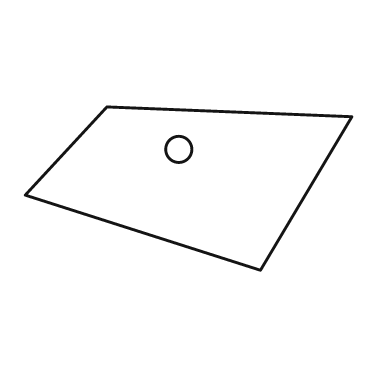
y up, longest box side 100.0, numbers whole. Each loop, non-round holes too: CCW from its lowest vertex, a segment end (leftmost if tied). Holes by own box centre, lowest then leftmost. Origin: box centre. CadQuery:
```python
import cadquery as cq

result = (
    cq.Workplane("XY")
    .moveTo(22.0, -25.0)
    .lineTo(50.0, 22.0)
    .lineTo(-25.0, 25.0)
    .lineTo(-50.0, -2.0)
    .close()
    .moveTo(-3.0, 12.0)
    .circle(4.0)
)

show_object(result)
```